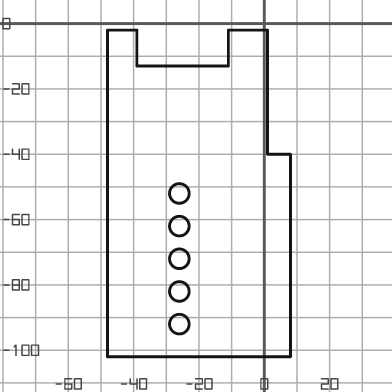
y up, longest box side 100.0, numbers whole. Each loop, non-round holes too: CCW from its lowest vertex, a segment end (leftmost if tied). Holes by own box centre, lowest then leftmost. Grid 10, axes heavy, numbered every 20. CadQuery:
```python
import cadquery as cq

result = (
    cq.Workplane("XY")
    .moveTo(-48.0, -102.0)
    .lineTo(8.0, -102.0)
    .lineTo(8.0, -40.0)
    .lineTo(1.0, -40.0)
    .lineTo(1.0, -2.0)
    .lineTo(-11.0, -2.0)
    .lineTo(-11.0, -13.0)
    .lineTo(-39.0, -13.0)
    .lineTo(-39.0, -2.0)
    .lineTo(-48.0, -2.0)
    .close()
    .moveTo(-26.0, -92.0)
    .circle(3.0)
    .moveTo(-26.0, -82.0)
    .circle(3.0)
    .moveTo(-26.0, -72.0)
    .circle(3.0)
    .moveTo(-26.0, -62.0)
    .circle(3.0)
    .moveTo(-26.0, -52.0)
    .circle(3.0)
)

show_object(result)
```